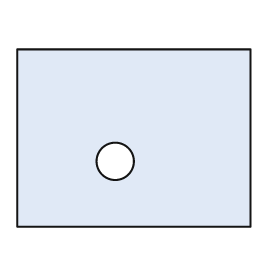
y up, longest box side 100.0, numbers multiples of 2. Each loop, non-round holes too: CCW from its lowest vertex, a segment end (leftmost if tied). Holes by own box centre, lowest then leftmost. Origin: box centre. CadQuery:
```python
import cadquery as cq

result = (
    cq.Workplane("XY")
    .moveTo(-50.0, -38.0)
    .lineTo(50.0, -38.0)
    .lineTo(50.0, 38.0)
    .lineTo(-50.0, 38.0)
    .close()
    .moveTo(-8.0, -10.0)
    .circle(8.0)
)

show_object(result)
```